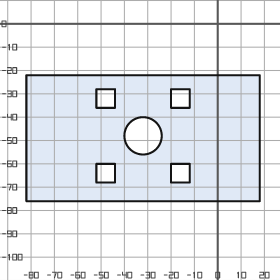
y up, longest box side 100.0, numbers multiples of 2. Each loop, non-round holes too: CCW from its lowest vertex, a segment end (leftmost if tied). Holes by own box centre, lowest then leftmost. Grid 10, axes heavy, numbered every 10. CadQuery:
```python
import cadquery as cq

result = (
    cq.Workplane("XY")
    .moveTo(-82.0, -76.0)
    .lineTo(18.0, -76.0)
    .lineTo(18.0, -22.0)
    .lineTo(-82.0, -22.0)
    .close()
    .moveTo(-52.0, -68.0)
    .lineTo(-44.0, -68.0)
    .lineTo(-44.0, -60.0)
    .lineTo(-52.0, -60.0)
    .close()
    .moveTo(-20.0, -68.0)
    .lineTo(-12.0, -68.0)
    .lineTo(-12.0, -60.0)
    .lineTo(-20.0, -60.0)
    .close()
    .moveTo(-32.0, -48.0)
    .circle(8.0)
    .moveTo(-52.0, -36.0)
    .lineTo(-44.0, -36.0)
    .lineTo(-44.0, -28.0)
    .lineTo(-52.0, -28.0)
    .close()
    .moveTo(-20.0, -36.0)
    .lineTo(-12.0, -36.0)
    .lineTo(-12.0, -28.0)
    .lineTo(-20.0, -28.0)
    .close()
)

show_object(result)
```